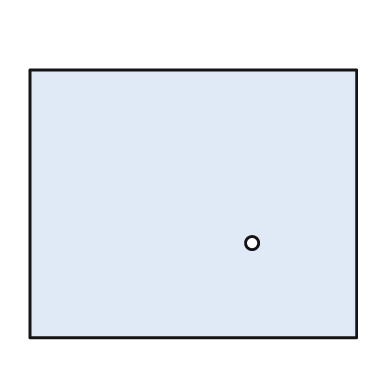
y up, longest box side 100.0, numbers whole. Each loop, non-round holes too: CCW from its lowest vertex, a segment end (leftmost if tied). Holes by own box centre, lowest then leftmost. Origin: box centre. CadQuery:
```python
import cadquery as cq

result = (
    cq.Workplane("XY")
    .moveTo(-50.0, -41.0)
    .lineTo(50.0, -41.0)
    .lineTo(50.0, 41.0)
    .lineTo(-50.0, 41.0)
    .close()
    .moveTo(18.0, -12.0)
    .circle(2.0)
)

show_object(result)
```